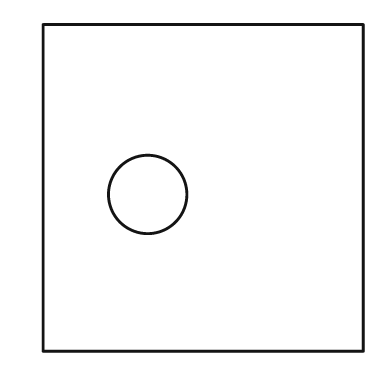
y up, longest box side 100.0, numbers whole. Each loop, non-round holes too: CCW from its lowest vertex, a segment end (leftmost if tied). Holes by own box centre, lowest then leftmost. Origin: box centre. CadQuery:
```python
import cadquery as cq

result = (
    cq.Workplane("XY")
    .moveTo(-49.0, -50.0)
    .lineTo(49.0, -50.0)
    .lineTo(49.0, 50.0)
    .lineTo(-49.0, 50.0)
    .close()
    .moveTo(-17.0, -2.0)
    .circle(12.0)
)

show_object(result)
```